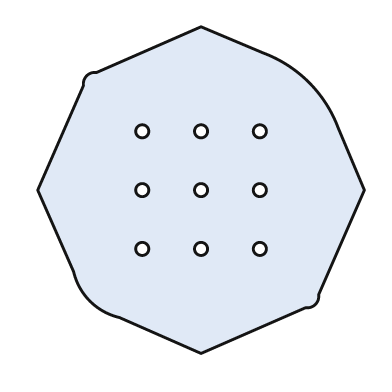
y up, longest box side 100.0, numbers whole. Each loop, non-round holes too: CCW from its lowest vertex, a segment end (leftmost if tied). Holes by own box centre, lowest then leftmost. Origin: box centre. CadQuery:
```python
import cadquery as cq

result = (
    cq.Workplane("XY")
    .moveTo(0.0, -50.0)
    .lineTo(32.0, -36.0)
    .threePointArc((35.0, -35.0), (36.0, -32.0))
    .lineTo(50.0, 0.0)
    .lineTo(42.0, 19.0)
    .threePointArc((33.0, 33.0), (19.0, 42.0))
    .lineTo(0.0, 50.0)
    .lineTo(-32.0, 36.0)
    .threePointArc((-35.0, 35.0), (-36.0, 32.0))
    .lineTo(-50.0, 0.0)
    .lineTo(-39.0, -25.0)
    .threePointArc((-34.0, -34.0), (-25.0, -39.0))
    .close()
    .moveTo(-18.0, -18.0)
    .circle(2.0)
    .moveTo(0.0, -18.0)
    .circle(2.0)
    .moveTo(18.0, -18.0)
    .circle(2.0)
    .moveTo(-18.0, 0.0)
    .circle(2.0)
    .moveTo(0.0, 0.0)
    .circle(2.0)
    .moveTo(18.0, 0.0)
    .circle(2.0)
    .moveTo(-18.0, 18.0)
    .circle(2.0)
    .moveTo(0.0, 18.0)
    .circle(2.0)
    .moveTo(18.0, 18.0)
    .circle(2.0)
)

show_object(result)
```